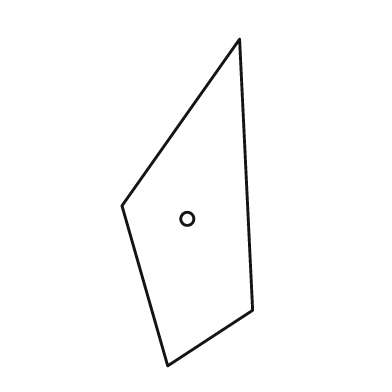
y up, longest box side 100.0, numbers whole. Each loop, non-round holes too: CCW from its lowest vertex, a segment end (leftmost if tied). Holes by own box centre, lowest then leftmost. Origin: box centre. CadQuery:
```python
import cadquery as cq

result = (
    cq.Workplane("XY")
    .moveTo(-6.0, -50.0)
    .lineTo(20.0, -33.0)
    .lineTo(16.0, 50.0)
    .lineTo(-20.0, -1.0)
    .close()
    .moveTo(0.0, -5.0)
    .circle(2.0)
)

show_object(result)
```